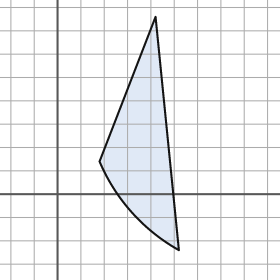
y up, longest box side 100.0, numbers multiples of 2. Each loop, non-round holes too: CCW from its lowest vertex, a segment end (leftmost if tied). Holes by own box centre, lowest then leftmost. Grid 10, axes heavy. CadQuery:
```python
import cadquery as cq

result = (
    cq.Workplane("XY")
    .moveTo(52.0, -24.0)
    .lineTo(42.0, 76.0)
    .lineTo(18.0, 14.0)
    .threePointArc((32.0, -8.0), (52.0, -24.0))
    .close()
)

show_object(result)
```